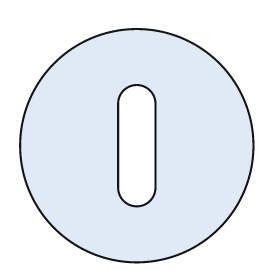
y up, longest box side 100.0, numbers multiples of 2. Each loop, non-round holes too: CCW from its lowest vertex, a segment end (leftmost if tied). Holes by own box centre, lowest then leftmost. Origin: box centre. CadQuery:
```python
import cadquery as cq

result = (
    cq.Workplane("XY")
    .moveTo(0.0, 0.0)
    .circle(50.0)
    .moveTo(-8.0, -18.0)
    .threePointArc((0.0, -26.0), (8.0, -18.0))
    .lineTo(8.0, 18.0)
    .threePointArc((0.0, 26.0), (-8.0, 18.0))
    .close()
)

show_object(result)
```